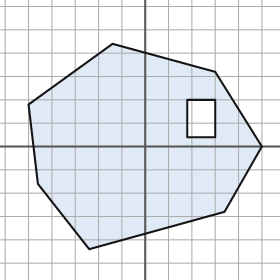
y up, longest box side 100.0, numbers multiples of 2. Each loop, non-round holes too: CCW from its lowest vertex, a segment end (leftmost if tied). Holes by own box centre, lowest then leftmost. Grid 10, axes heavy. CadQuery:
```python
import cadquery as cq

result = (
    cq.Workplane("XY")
    .moveTo(-24.0, -44.0)
    .lineTo(34.0, -28.0)
    .lineTo(50.0, 0.0)
    .lineTo(30.0, 32.0)
    .lineTo(-14.0, 44.0)
    .lineTo(-50.0, 18.0)
    .lineTo(-46.0, -16.0)
    .close()
    .moveTo(18.0, 4.0)
    .lineTo(30.0, 4.0)
    .lineTo(30.0, 20.0)
    .lineTo(18.0, 20.0)
    .close()
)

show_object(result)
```